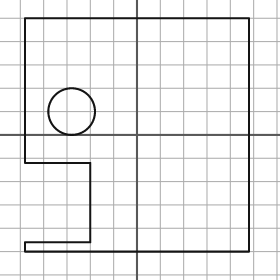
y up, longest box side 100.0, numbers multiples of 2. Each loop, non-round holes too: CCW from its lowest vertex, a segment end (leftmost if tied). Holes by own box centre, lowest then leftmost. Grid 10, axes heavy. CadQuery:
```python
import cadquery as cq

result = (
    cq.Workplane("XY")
    .moveTo(-48.0, -50.0)
    .lineTo(48.0, -50.0)
    .lineTo(48.0, 50.0)
    .lineTo(-48.0, 50.0)
    .lineTo(-48.0, -12.0)
    .lineTo(-20.0, -12.0)
    .lineTo(-20.0, -46.0)
    .lineTo(-48.0, -46.0)
    .close()
    .moveTo(-28.0, 10.0)
    .circle(10.0)
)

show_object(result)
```